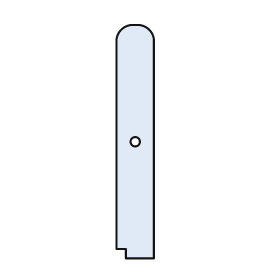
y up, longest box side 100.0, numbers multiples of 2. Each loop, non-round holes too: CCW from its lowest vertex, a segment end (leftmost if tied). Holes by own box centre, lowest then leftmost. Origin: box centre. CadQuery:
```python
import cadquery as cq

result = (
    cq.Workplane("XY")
    .moveTo(-4.0, -50.0)
    .lineTo(8.0, -50.0)
    .lineTo(8.0, 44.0)
    .threePointArc((6.0, 48.0), (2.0, 50.0))
    .lineTo(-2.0, 50.0)
    .threePointArc((-6.0, 48.0), (-8.0, 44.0))
    .lineTo(-8.0, -46.0)
    .lineTo(-4.0, -46.0)
    .close()
    .moveTo(0.0, 0.0)
    .circle(2.0)
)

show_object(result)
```